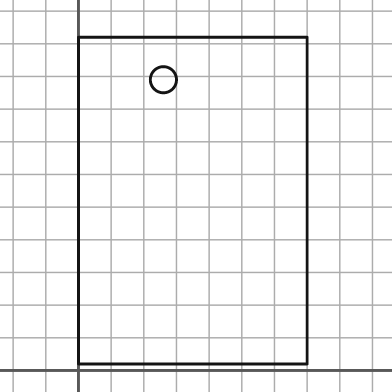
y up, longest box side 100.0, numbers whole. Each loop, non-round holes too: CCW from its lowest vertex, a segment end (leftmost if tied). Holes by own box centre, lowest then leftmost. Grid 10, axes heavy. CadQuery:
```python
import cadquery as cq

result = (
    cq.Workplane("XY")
    .moveTo(0.0, 2.0)
    .lineTo(70.0, 2.0)
    .lineTo(70.0, 102.0)
    .lineTo(0.0, 102.0)
    .close()
    .moveTo(26.0, 89.0)
    .circle(4.0)
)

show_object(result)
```